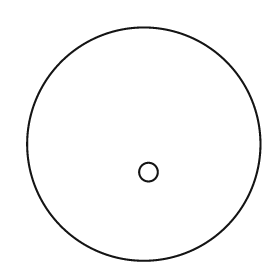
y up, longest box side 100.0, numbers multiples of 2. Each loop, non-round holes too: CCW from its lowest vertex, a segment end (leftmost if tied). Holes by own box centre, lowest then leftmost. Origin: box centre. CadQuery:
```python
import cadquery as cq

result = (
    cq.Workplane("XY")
    .moveTo(0.0, 0.0)
    .circle(50.0)
    .moveTo(2.0, -12.0)
    .circle(4.0)
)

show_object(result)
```